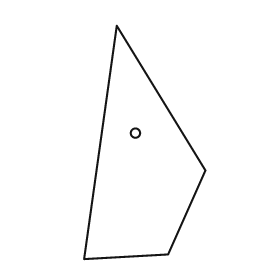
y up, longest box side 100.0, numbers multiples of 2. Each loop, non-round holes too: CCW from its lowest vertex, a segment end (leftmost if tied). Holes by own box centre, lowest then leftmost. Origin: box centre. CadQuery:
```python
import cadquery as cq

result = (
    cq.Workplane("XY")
    .moveTo(-26.0, -50.0)
    .lineTo(10.0, -48.0)
    .lineTo(26.0, -12.0)
    .lineTo(-12.0, 50.0)
    .close()
    .moveTo(-4.0, 4.0)
    .circle(2.0)
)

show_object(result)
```